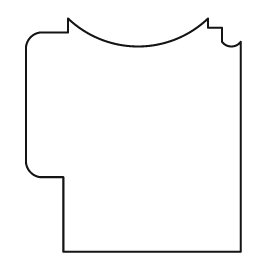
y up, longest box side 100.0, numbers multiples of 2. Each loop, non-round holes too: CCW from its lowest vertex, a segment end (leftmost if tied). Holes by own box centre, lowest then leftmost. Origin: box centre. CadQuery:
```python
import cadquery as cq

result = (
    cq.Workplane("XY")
    .moveTo(-30.0, -50.0)
    .lineTo(46.0, -50.0)
    .lineTo(46.0, 40.0)
    .threePointArc((42.0, 38.0), (38.0, 40.0))
    .lineTo(38.0, 46.0)
    .lineTo(32.0, 46.0)
    .lineTo(32.0, 50.0)
    .threePointArc((2.0, 38.0), (-28.0, 50.0))
    .lineTo(-28.0, 44.0)
    .lineTo(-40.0, 44.0)
    .threePointArc((-44.0, 42.0), (-46.0, 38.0))
    .lineTo(-46.0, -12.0)
    .threePointArc((-44.0, -16.0), (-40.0, -18.0))
    .lineTo(-30.0, -18.0)
    .close()
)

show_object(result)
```